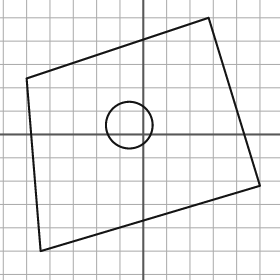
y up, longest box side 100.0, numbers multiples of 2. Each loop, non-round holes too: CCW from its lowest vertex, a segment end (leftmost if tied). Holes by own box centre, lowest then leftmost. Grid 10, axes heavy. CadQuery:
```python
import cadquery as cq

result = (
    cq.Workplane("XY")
    .moveTo(-44.0, -50.0)
    .lineTo(50.0, -22.0)
    .lineTo(28.0, 50.0)
    .lineTo(-50.0, 24.0)
    .close()
    .moveTo(-6.0, 4.0)
    .circle(10.0)
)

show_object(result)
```